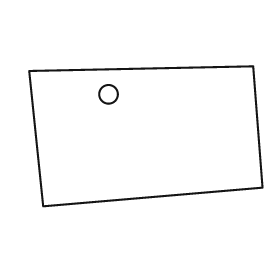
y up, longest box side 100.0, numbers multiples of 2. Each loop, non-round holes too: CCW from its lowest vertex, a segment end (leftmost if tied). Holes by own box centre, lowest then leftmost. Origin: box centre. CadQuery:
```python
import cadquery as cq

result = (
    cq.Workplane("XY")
    .moveTo(-44.0, -30.0)
    .lineTo(50.0, -22.0)
    .lineTo(46.0, 30.0)
    .lineTo(-50.0, 28.0)
    .close()
    .moveTo(-16.0, 18.0)
    .circle(4.0)
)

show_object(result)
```